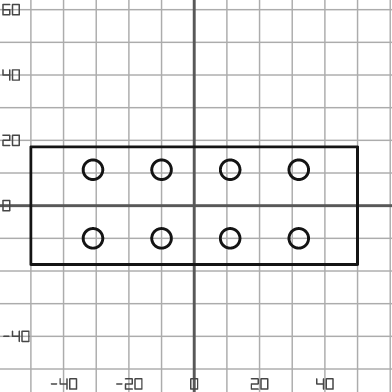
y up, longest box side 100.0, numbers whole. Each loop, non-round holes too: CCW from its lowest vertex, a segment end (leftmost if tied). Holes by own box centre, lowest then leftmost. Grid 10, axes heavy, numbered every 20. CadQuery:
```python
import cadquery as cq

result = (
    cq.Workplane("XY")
    .moveTo(-50.0, -18.0)
    .lineTo(50.0, -18.0)
    .lineTo(50.0, 18.0)
    .lineTo(-50.0, 18.0)
    .close()
    .moveTo(-31.0, -10.0)
    .circle(3.0)
    .moveTo(-10.0, -10.0)
    .circle(3.0)
    .moveTo(11.0, -10.0)
    .circle(3.0)
    .moveTo(32.0, -10.0)
    .circle(3.0)
    .moveTo(-31.0, 11.0)
    .circle(3.0)
    .moveTo(-10.0, 11.0)
    .circle(3.0)
    .moveTo(11.0, 11.0)
    .circle(3.0)
    .moveTo(32.0, 11.0)
    .circle(3.0)
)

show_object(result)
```